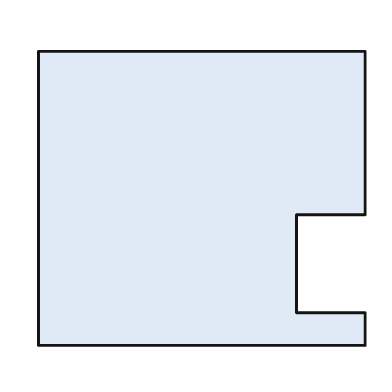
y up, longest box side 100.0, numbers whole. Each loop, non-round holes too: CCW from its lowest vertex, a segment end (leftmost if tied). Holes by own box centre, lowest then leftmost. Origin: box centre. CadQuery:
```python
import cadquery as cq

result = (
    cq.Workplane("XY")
    .moveTo(-50.0, -45.0)
    .lineTo(50.0, -45.0)
    .lineTo(50.0, -35.0)
    .lineTo(29.0, -35.0)
    .lineTo(29.0, -5.0)
    .lineTo(50.0, -5.0)
    .lineTo(50.0, 45.0)
    .lineTo(-50.0, 45.0)
    .close()
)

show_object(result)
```